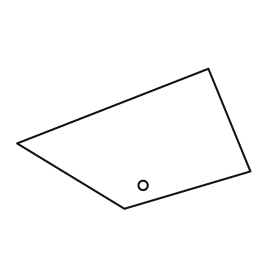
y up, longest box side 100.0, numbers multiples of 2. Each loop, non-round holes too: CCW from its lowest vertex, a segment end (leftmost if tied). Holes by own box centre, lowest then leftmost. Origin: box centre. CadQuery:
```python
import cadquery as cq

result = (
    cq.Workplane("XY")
    .moveTo(-4.0, -30.0)
    .lineTo(50.0, -14.0)
    .lineTo(32.0, 30.0)
    .lineTo(-50.0, -2.0)
    .close()
    .moveTo(4.0, -20.0)
    .circle(2.0)
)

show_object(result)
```